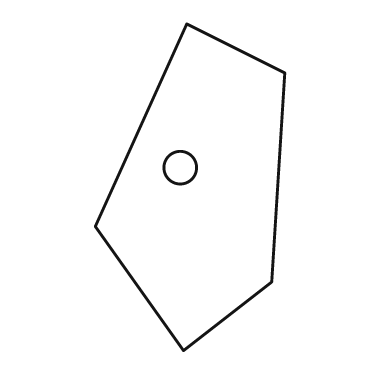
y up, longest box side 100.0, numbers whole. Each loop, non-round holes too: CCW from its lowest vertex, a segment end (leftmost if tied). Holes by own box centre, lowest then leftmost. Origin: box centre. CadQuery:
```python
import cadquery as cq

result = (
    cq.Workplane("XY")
    .moveTo(-2.0, -50.0)
    .lineTo(25.0, -29.0)
    .lineTo(29.0, 35.0)
    .lineTo(-1.0, 50.0)
    .lineTo(-29.0, -12.0)
    .close()
    .moveTo(-3.0, 6.0)
    .circle(5.0)
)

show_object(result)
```